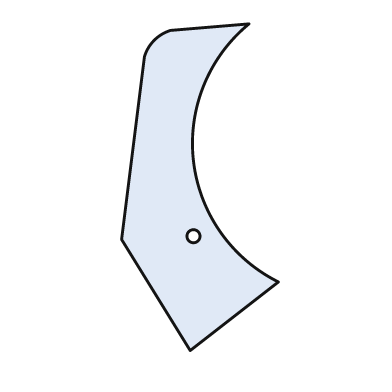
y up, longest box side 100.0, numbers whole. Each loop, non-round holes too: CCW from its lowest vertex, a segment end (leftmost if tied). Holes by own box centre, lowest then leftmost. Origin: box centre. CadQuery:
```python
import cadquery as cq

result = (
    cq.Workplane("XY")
    .moveTo(-3.0, -50.0)
    .lineTo(24.0, -29.0)
    .threePointArc((-2.0, 8.0), (15.0, 50.0))
    .lineTo(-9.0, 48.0)
    .threePointArc((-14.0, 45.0), (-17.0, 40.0))
    .lineTo(-24.0, -16.0)
    .close()
    .moveTo(-2.0, -15.0)
    .circle(2.0)
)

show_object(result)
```